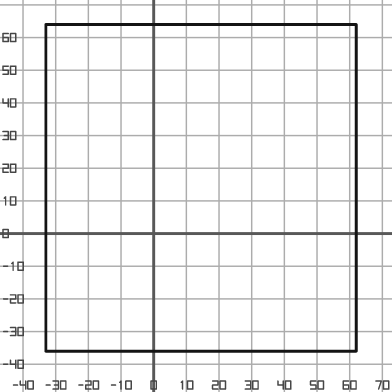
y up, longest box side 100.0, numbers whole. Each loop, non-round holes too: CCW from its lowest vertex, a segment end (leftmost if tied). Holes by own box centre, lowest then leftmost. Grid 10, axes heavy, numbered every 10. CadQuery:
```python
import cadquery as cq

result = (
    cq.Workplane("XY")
    .moveTo(-33.0, -36.0)
    .lineTo(62.0, -36.0)
    .lineTo(62.0, 64.0)
    .lineTo(-33.0, 64.0)
    .close()
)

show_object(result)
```